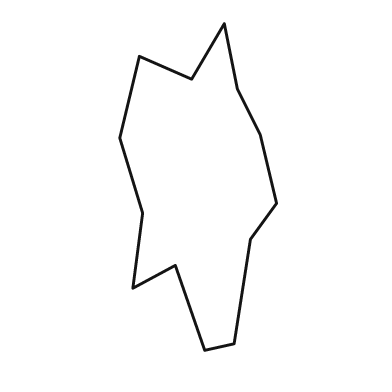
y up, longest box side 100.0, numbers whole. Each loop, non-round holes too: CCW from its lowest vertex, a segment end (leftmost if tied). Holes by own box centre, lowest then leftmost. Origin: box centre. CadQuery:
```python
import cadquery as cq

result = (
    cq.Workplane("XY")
    .moveTo(2.0, -50.0)
    .lineTo(11.0, -48.0)
    .lineTo(16.0, -16.0)
    .lineTo(24.0, -5.0)
    .lineTo(19.0, 16.0)
    .lineTo(12.0, 30.0)
    .lineTo(8.0, 50.0)
    .lineTo(-2.0, 33.0)
    .lineTo(-18.0, 40.0)
    .lineTo(-24.0, 15.0)
    .lineTo(-17.0, -8.0)
    .lineTo(-20.0, -31.0)
    .lineTo(-7.0, -24.0)
    .close()
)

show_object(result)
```